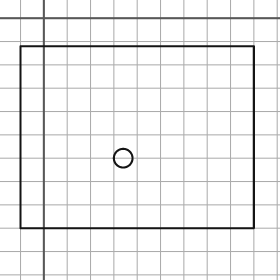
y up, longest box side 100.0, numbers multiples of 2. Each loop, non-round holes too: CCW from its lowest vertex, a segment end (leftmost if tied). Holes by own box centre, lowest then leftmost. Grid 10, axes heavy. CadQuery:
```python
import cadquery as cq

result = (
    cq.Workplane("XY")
    .moveTo(-10.0, -90.0)
    .lineTo(90.0, -90.0)
    .lineTo(90.0, -12.0)
    .lineTo(-10.0, -12.0)
    .close()
    .moveTo(34.0, -60.0)
    .circle(4.0)
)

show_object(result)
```